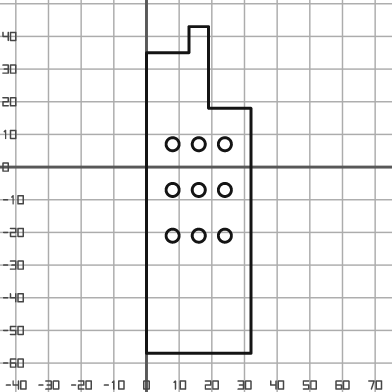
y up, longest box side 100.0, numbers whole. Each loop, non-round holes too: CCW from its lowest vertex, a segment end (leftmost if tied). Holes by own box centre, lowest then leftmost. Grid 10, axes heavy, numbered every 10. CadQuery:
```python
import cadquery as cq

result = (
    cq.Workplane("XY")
    .moveTo(0.0, -57.0)
    .lineTo(32.0, -57.0)
    .lineTo(32.0, 18.0)
    .lineTo(19.0, 18.0)
    .lineTo(19.0, 43.0)
    .lineTo(13.0, 43.0)
    .lineTo(13.0, 35.0)
    .lineTo(0.0, 35.0)
    .close()
    .moveTo(8.0, -21.0)
    .circle(2.0)
    .moveTo(16.0, -21.0)
    .circle(2.0)
    .moveTo(24.0, -21.0)
    .circle(2.0)
    .moveTo(8.0, -7.0)
    .circle(2.0)
    .moveTo(16.0, -7.0)
    .circle(2.0)
    .moveTo(24.0, -7.0)
    .circle(2.0)
    .moveTo(8.0, 7.0)
    .circle(2.0)
    .moveTo(16.0, 7.0)
    .circle(2.0)
    .moveTo(24.0, 7.0)
    .circle(2.0)
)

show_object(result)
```